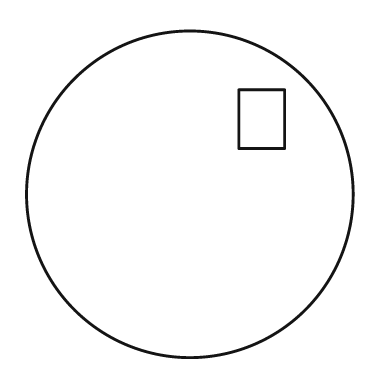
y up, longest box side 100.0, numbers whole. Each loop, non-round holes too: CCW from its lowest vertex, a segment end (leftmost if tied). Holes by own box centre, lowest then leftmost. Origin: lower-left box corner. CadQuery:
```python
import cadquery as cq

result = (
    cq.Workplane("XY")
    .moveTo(50.0, 50.0)
    .circle(50.0)
    .moveTo(65.0, 64.0)
    .lineTo(79.0, 64.0)
    .lineTo(79.0, 82.0)
    .lineTo(65.0, 82.0)
    .close()
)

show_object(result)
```